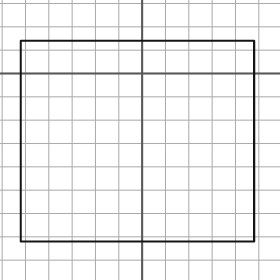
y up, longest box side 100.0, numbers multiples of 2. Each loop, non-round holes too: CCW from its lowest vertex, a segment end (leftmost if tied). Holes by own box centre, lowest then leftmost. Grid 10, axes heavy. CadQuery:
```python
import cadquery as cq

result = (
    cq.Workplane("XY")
    .moveTo(-52.0, -72.0)
    .lineTo(48.0, -72.0)
    .lineTo(48.0, 14.0)
    .lineTo(-52.0, 14.0)
    .close()
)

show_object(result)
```